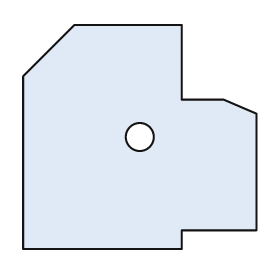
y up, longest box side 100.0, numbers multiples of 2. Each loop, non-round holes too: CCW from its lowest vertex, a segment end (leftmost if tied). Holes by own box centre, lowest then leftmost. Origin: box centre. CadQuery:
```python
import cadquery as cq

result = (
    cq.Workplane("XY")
    .moveTo(-50.0, -48.0)
    .lineTo(18.0, -48.0)
    .lineTo(18.0, -40.0)
    .lineTo(50.0, -40.0)
    .lineTo(50.0, 10.0)
    .lineTo(36.0, 16.0)
    .lineTo(18.0, 16.0)
    .lineTo(18.0, 48.0)
    .lineTo(-28.0, 48.0)
    .lineTo(-50.0, 26.0)
    .close()
    .moveTo(0.0, 0.0)
    .circle(6.0)
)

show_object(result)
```